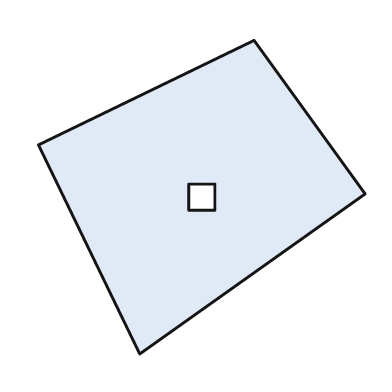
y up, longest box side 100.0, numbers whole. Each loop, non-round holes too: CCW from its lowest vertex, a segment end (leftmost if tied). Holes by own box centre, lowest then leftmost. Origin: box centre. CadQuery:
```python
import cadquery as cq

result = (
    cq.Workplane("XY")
    .moveTo(-19.0, -48.0)
    .lineTo(50.0, 1.0)
    .lineTo(16.0, 48.0)
    .lineTo(-50.0, 16.0)
    .close()
    .moveTo(-4.0, -4.0)
    .lineTo(4.0, -4.0)
    .lineTo(4.0, 4.0)
    .lineTo(-4.0, 4.0)
    .close()
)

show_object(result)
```